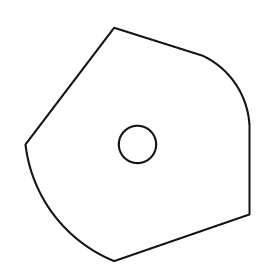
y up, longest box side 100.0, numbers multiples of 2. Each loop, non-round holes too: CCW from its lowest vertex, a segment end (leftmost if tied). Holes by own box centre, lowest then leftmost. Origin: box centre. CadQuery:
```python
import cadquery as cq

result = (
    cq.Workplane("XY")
    .moveTo(-10.0, -50.0)
    .lineTo(48.0, -30.0)
    .lineTo(48.0, 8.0)
    .threePointArc((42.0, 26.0), (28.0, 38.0))
    .lineTo(-10.0, 50.0)
    .lineTo(-48.0, 0.0)
    .threePointArc((-36.0, -30.0), (-10.0, -50.0))
    .close()
    .moveTo(0.0, 0.0)
    .circle(8.0)
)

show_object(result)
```